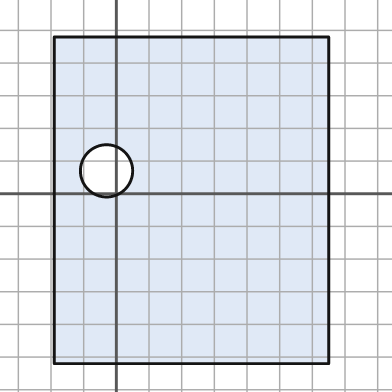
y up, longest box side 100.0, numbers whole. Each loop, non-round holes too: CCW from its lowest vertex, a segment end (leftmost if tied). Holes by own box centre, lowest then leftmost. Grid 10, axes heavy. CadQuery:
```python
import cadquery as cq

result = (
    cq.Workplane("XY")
    .moveTo(-19.0, -52.0)
    .lineTo(65.0, -52.0)
    .lineTo(65.0, 48.0)
    .lineTo(-19.0, 48.0)
    .close()
    .moveTo(-3.0, 7.0)
    .circle(8.0)
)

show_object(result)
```